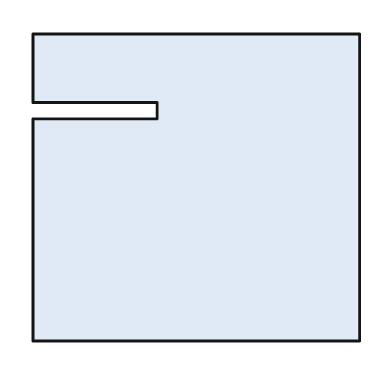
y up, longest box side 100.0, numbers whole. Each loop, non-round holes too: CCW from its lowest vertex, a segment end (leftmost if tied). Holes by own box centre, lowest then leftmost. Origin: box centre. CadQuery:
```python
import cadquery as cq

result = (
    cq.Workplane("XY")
    .moveTo(-50.0, -47.0)
    .lineTo(50.0, -47.0)
    .lineTo(50.0, 47.0)
    .lineTo(-50.0, 47.0)
    .lineTo(-50.0, 26.0)
    .lineTo(-12.0, 26.0)
    .lineTo(-12.0, 21.0)
    .lineTo(-50.0, 21.0)
    .close()
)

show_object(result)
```